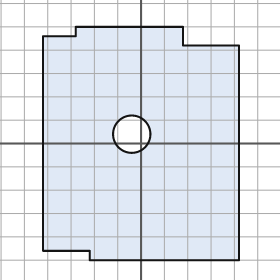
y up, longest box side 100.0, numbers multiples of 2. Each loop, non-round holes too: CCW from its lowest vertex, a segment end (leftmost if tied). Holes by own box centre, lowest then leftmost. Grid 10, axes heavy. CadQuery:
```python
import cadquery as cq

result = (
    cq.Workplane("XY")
    .moveTo(-22.0, -50.0)
    .lineTo(42.0, -50.0)
    .lineTo(42.0, 42.0)
    .lineTo(18.0, 42.0)
    .lineTo(18.0, 50.0)
    .lineTo(-28.0, 50.0)
    .lineTo(-28.0, 46.0)
    .lineTo(-42.0, 46.0)
    .lineTo(-42.0, -46.0)
    .lineTo(-22.0, -46.0)
    .close()
    .moveTo(-4.0, 4.0)
    .circle(8.0)
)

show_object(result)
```